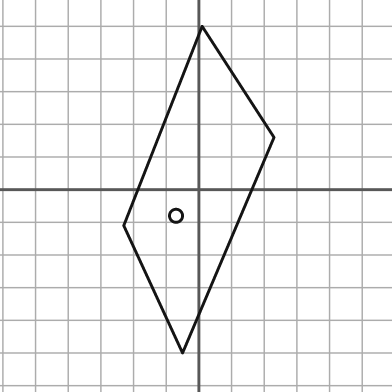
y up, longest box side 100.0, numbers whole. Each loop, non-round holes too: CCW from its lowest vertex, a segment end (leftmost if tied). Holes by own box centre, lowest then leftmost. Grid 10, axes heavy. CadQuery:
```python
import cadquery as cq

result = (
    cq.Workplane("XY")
    .moveTo(-5.0, -50.0)
    .lineTo(23.0, 16.0)
    .lineTo(1.0, 50.0)
    .lineTo(-23.0, -11.0)
    .close()
    .moveTo(-7.0, -8.0)
    .circle(2.0)
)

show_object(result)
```